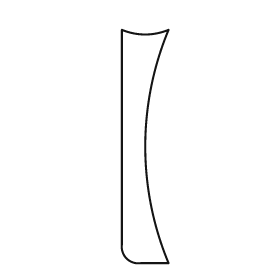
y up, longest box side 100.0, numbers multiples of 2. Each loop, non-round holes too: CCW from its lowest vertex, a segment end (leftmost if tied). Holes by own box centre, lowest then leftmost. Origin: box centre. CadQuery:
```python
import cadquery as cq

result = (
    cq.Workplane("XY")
    .moveTo(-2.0, -50.0)
    .lineTo(10.0, -50.0)
    .threePointArc((0.0, 0.0), (10.0, 50.0))
    .threePointArc((0.0, 48.0), (-10.0, 50.0))
    .lineTo(-10.0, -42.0)
    .threePointArc((-8.0, -48.0), (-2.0, -50.0))
    .close()
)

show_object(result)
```